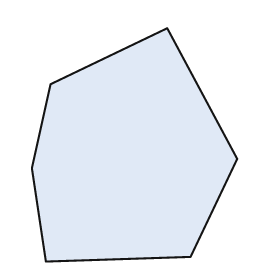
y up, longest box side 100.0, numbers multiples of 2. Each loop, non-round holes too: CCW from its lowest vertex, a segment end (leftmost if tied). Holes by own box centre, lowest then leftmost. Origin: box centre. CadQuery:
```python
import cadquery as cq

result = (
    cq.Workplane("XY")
    .moveTo(-38.0, -50.0)
    .lineTo(24.0, -48.0)
    .lineTo(44.0, -6.0)
    .lineTo(14.0, 50.0)
    .lineTo(-36.0, 26.0)
    .lineTo(-44.0, -10.0)
    .close()
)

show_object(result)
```